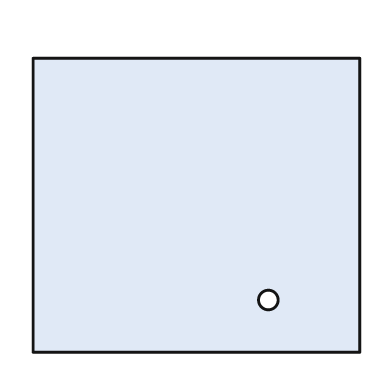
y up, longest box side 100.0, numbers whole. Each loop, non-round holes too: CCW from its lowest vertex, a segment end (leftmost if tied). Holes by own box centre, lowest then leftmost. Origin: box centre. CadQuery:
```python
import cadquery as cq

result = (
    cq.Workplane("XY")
    .moveTo(-50.0, -45.0)
    .lineTo(50.0, -45.0)
    .lineTo(50.0, 45.0)
    .lineTo(-50.0, 45.0)
    .close()
    .moveTo(22.0, -29.0)
    .circle(3.0)
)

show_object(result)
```